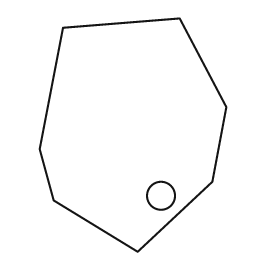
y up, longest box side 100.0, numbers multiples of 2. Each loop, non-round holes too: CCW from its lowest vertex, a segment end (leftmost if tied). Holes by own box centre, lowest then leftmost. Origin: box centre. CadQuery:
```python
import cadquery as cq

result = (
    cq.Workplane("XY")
    .moveTo(2.0, -50.0)
    .lineTo(34.0, -20.0)
    .lineTo(40.0, 12.0)
    .lineTo(20.0, 50.0)
    .lineTo(-30.0, 46.0)
    .lineTo(-40.0, -6.0)
    .lineTo(-34.0, -28.0)
    .close()
    .moveTo(12.0, -26.0)
    .circle(6.0)
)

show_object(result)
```